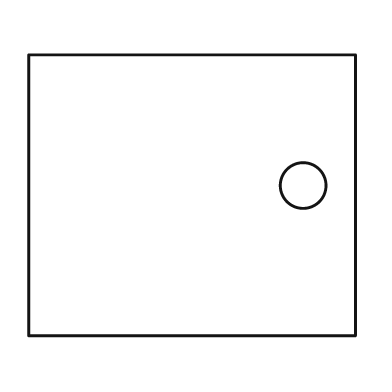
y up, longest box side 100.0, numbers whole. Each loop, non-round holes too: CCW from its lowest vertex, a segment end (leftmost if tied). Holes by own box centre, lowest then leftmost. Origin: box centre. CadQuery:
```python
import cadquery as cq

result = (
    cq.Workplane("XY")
    .moveTo(-50.0, -43.0)
    .lineTo(50.0, -43.0)
    .lineTo(50.0, 43.0)
    .lineTo(-50.0, 43.0)
    .close()
    .moveTo(34.0, 3.0)
    .circle(7.0)
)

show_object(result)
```